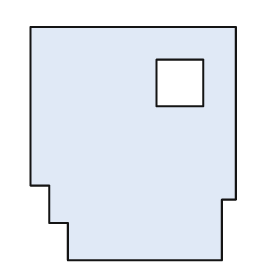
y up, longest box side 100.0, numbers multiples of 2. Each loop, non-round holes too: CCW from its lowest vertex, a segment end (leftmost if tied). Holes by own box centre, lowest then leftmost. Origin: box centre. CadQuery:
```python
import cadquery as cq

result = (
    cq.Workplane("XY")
    .moveTo(-28.0, -50.0)
    .lineTo(38.0, -50.0)
    .lineTo(38.0, -24.0)
    .lineTo(44.0, -24.0)
    .lineTo(44.0, 50.0)
    .lineTo(-44.0, 50.0)
    .lineTo(-44.0, -18.0)
    .lineTo(-36.0, -18.0)
    .lineTo(-36.0, -34.0)
    .lineTo(-28.0, -34.0)
    .close()
    .moveTo(10.0, 16.0)
    .lineTo(30.0, 16.0)
    .lineTo(30.0, 36.0)
    .lineTo(10.0, 36.0)
    .close()
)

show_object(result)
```